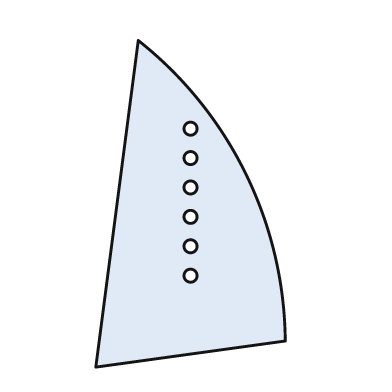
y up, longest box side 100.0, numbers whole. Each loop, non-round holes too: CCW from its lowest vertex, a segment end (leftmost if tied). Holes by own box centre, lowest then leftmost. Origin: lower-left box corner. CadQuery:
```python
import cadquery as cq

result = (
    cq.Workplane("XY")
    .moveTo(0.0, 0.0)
    .lineTo(58.0, 8.0)
    .threePointArc((46.0, 59.0), (13.0, 100.0))
    .close()
    .moveTo(29.0, 28.0)
    .circle(2.0)
    .moveTo(29.0, 37.0)
    .circle(2.0)
    .moveTo(29.0, 46.0)
    .circle(2.0)
    .moveTo(29.0, 55.0)
    .circle(2.0)
    .moveTo(29.0, 64.0)
    .circle(2.0)
    .moveTo(29.0, 73.0)
    .circle(2.0)
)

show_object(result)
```